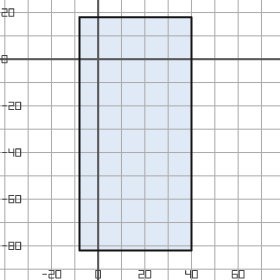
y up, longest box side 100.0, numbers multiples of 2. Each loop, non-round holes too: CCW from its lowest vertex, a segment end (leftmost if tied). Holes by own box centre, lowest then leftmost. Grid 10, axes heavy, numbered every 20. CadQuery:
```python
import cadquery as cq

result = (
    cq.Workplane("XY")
    .moveTo(-8.0, -82.0)
    .lineTo(40.0, -82.0)
    .lineTo(40.0, 18.0)
    .lineTo(-8.0, 18.0)
    .close()
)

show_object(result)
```